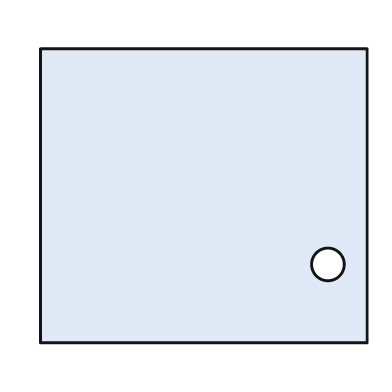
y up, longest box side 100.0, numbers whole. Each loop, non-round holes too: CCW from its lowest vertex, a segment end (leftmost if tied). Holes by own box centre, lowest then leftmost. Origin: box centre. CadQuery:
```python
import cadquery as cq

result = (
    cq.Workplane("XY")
    .moveTo(-50.0, -45.0)
    .lineTo(50.0, -45.0)
    .lineTo(50.0, 45.0)
    .lineTo(-50.0, 45.0)
    .close()
    .moveTo(38.0, -21.0)
    .circle(5.0)
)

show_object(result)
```